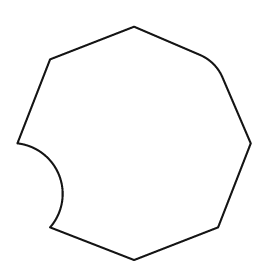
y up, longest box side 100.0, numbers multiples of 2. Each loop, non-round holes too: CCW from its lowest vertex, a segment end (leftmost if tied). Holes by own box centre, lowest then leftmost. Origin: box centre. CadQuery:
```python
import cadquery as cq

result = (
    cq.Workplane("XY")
    .moveTo(0.0, -50.0)
    .lineTo(36.0, -36.0)
    .lineTo(50.0, 0.0)
    .lineTo(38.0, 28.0)
    .threePointArc((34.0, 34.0), (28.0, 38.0))
    .lineTo(0.0, 50.0)
    .lineTo(-36.0, 36.0)
    .lineTo(-50.0, 0.0)
    .threePointArc((-32.0, -14.0), (-36.0, -36.0))
    .close()
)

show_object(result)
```